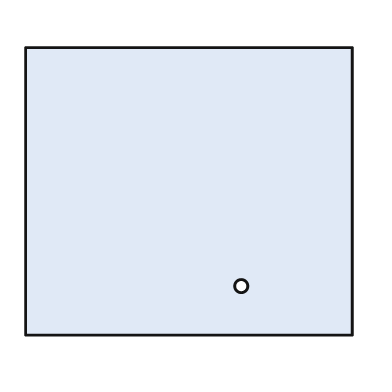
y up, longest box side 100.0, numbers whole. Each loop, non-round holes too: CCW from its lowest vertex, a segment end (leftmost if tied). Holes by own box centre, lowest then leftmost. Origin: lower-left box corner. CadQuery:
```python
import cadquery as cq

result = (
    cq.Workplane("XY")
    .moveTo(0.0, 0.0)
    .lineTo(100.0, 0.0)
    .lineTo(100.0, 88.0)
    .lineTo(0.0, 88.0)
    .close()
    .moveTo(66.0, 15.0)
    .circle(2.0)
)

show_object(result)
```